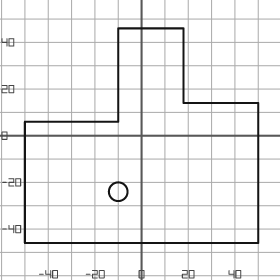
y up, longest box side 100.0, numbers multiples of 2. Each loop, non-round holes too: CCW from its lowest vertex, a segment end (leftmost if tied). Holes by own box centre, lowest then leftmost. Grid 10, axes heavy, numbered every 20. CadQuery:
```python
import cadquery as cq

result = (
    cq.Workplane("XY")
    .moveTo(-50.0, -46.0)
    .lineTo(50.0, -46.0)
    .lineTo(50.0, 14.0)
    .lineTo(18.0, 14.0)
    .lineTo(18.0, 46.0)
    .lineTo(-10.0, 46.0)
    .lineTo(-10.0, 6.0)
    .lineTo(-50.0, 6.0)
    .close()
    .moveTo(-10.0, -24.0)
    .circle(4.0)
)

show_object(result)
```